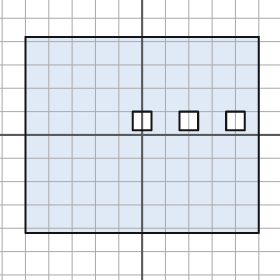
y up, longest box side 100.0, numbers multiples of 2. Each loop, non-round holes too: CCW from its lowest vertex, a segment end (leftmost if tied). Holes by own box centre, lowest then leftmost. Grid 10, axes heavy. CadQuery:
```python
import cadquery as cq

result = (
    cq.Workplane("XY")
    .moveTo(-50.0, -42.0)
    .lineTo(50.0, -42.0)
    .lineTo(50.0, 42.0)
    .lineTo(-50.0, 42.0)
    .close()
    .moveTo(-4.0, 2.0)
    .lineTo(4.0, 2.0)
    .lineTo(4.0, 10.0)
    .lineTo(-4.0, 10.0)
    .close()
    .moveTo(16.0, 2.0)
    .lineTo(24.0, 2.0)
    .lineTo(24.0, 10.0)
    .lineTo(16.0, 10.0)
    .close()
    .moveTo(36.0, 2.0)
    .lineTo(44.0, 2.0)
    .lineTo(44.0, 10.0)
    .lineTo(36.0, 10.0)
    .close()
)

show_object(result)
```